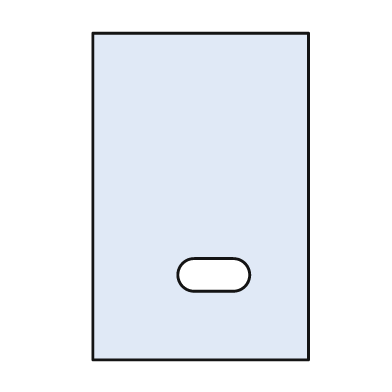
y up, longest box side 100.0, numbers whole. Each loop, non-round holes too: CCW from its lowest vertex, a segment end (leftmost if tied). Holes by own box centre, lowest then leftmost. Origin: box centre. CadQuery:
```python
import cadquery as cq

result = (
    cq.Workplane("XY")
    .moveTo(-33.0, -50.0)
    .lineTo(33.0, -50.0)
    .lineTo(33.0, 50.0)
    .lineTo(-33.0, 50.0)
    .close()
    .moveTo(-2.0, -29.0)
    .lineTo(10.0, -29.0)
    .threePointArc((15.0, -24.0), (10.0, -19.0))
    .lineTo(-2.0, -19.0)
    .threePointArc((-7.0, -24.0), (-2.0, -29.0))
    .close()
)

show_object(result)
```